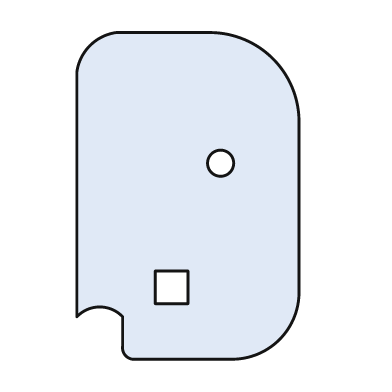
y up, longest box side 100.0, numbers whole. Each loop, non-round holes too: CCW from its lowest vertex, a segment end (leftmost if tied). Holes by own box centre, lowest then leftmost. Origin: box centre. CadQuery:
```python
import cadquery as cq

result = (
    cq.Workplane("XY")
    .moveTo(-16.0, -50.0)
    .lineTo(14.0, -50.0)
    .threePointArc((28.0, -44.0), (34.0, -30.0))
    .lineTo(34.0, 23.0)
    .threePointArc((26.0, 42.0), (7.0, 50.0))
    .lineTo(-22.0, 50.0)
    .threePointArc((-30.0, 46.0), (-34.0, 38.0))
    .lineTo(-34.0, -37.0)
    .threePointArc((-27.0, -34.0), (-20.0, -37.0))
    .lineTo(-20.0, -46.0)
    .threePointArc((-19.0, -49.0), (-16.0, -50.0))
    .close()
    .moveTo(-10.0, -33.0)
    .lineTo(0.0, -33.0)
    .lineTo(0.0, -23.0)
    .lineTo(-10.0, -23.0)
    .close()
    .moveTo(10.0, 10.0)
    .circle(4.0)
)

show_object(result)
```